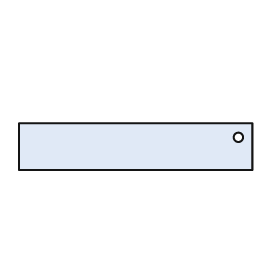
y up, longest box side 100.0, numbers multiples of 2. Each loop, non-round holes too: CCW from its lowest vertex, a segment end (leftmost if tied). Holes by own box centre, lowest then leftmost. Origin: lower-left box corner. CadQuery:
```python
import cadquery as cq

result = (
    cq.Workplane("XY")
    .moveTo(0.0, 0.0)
    .lineTo(100.0, 0.0)
    .lineTo(100.0, 20.0)
    .lineTo(0.0, 20.0)
    .close()
    .moveTo(94.0, 14.0)
    .circle(2.0)
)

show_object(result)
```